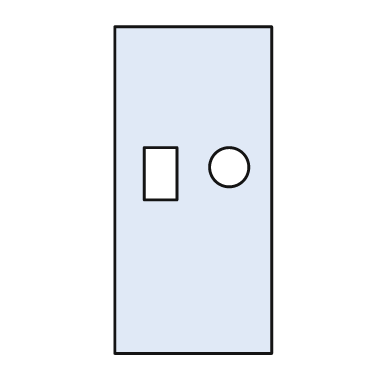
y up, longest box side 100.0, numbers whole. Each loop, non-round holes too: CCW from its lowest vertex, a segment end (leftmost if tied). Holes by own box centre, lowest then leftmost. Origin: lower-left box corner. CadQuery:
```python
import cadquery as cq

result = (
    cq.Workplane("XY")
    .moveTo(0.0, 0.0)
    .lineTo(48.0, 0.0)
    .lineTo(48.0, 100.0)
    .lineTo(0.0, 100.0)
    .close()
    .moveTo(9.0, 47.0)
    .lineTo(19.0, 47.0)
    .lineTo(19.0, 63.0)
    .lineTo(9.0, 63.0)
    .close()
    .moveTo(35.0, 57.0)
    .circle(6.0)
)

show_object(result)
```